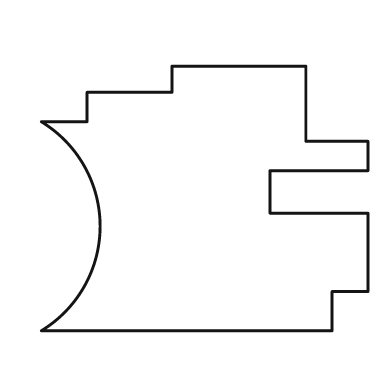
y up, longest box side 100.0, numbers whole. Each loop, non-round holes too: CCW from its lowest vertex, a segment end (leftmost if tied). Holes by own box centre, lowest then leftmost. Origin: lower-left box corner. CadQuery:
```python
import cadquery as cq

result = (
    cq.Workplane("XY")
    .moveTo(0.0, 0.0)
    .lineTo(89.0, 0.0)
    .lineTo(89.0, 12.0)
    .lineTo(100.0, 12.0)
    .lineTo(100.0, 36.0)
    .lineTo(70.0, 36.0)
    .lineTo(70.0, 49.0)
    .lineTo(100.0, 49.0)
    .lineTo(100.0, 58.0)
    .lineTo(81.0, 58.0)
    .lineTo(81.0, 81.0)
    .lineTo(40.0, 81.0)
    .lineTo(40.0, 73.0)
    .lineTo(14.0, 73.0)
    .lineTo(14.0, 64.0)
    .lineTo(0.0, 64.0)
    .threePointArc((18.0, 32.0), (0.0, 0.0))
    .close()
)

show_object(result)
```